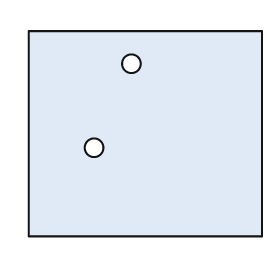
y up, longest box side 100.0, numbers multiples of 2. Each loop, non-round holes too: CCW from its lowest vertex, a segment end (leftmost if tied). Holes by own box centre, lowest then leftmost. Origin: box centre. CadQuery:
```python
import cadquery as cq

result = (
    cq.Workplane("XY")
    .moveTo(-50.0, -44.0)
    .lineTo(50.0, -44.0)
    .lineTo(50.0, 44.0)
    .lineTo(-50.0, 44.0)
    .close()
    .moveTo(-22.0, -6.0)
    .circle(4.0)
    .moveTo(-6.0, 30.0)
    .circle(4.0)
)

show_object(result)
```